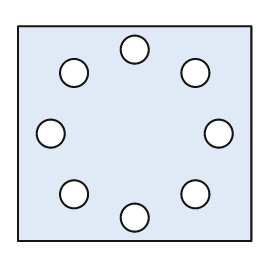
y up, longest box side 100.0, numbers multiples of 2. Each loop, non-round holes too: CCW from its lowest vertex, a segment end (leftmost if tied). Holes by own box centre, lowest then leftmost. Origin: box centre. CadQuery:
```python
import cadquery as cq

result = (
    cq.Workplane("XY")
    .moveTo(-50.0, -46.0)
    .lineTo(50.0, -46.0)
    .lineTo(50.0, 46.0)
    .lineTo(-50.0, 46.0)
    .close()
    .moveTo(0.0, -36.0)
    .circle(6.0)
    .moveTo(-26.0, -26.0)
    .circle(6.0)
    .moveTo(26.0, -26.0)
    .circle(6.0)
    .moveTo(-36.0, 0.0)
    .circle(6.0)
    .moveTo(36.0, 0.0)
    .circle(6.0)
    .moveTo(-26.0, 26.0)
    .circle(6.0)
    .moveTo(26.0, 26.0)
    .circle(6.0)
    .moveTo(0.0, 36.0)
    .circle(6.0)
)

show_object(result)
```